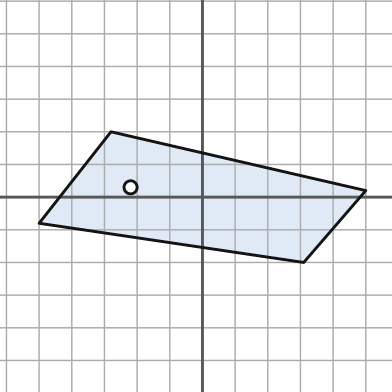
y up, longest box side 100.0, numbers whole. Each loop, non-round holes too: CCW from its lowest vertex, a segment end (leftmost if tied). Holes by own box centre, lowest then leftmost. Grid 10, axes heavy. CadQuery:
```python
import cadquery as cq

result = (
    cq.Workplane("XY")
    .moveTo(31.0, -20.0)
    .lineTo(50.0, 2.0)
    .lineTo(-28.0, 20.0)
    .lineTo(-50.0, -8.0)
    .close()
    .moveTo(-22.0, 3.0)
    .circle(2.0)
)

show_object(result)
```